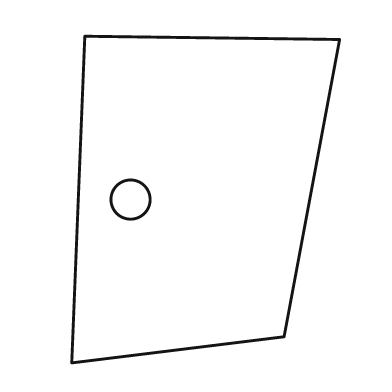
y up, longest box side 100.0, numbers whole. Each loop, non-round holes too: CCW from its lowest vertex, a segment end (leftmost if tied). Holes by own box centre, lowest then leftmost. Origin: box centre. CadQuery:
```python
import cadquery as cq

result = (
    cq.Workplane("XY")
    .moveTo(-41.0, -50.0)
    .lineTo(24.0, -42.0)
    .lineTo(41.0, 49.0)
    .lineTo(-37.0, 50.0)
    .close()
    .moveTo(-23.0, 0.0)
    .circle(6.0)
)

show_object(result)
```